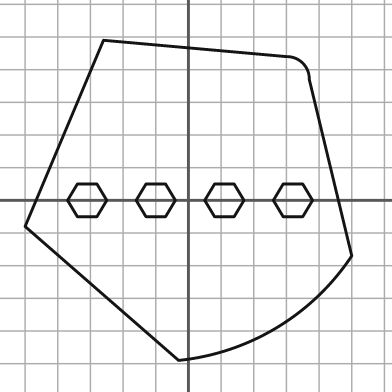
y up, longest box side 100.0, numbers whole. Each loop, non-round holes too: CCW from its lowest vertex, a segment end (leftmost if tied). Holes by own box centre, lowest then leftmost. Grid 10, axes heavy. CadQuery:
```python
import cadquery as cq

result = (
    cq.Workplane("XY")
    .moveTo(-3.0, -49.0)
    .threePointArc((27.0, -39.0), (50.0, -17.0))
    .lineTo(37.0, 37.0)
    .threePointArc((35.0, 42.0), (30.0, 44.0))
    .lineTo(-26.0, 49.0)
    .lineTo(-50.0, -8.0)
    .close()
    .moveTo(-34.0, -5.0)
    .lineTo(-28.0, -5.0)
    .lineTo(-25.0, 0.0)
    .lineTo(-28.0, 5.0)
    .lineTo(-34.0, 5.0)
    .lineTo(-37.0, 0.0)
    .close()
    .moveTo(-13.0, -5.0)
    .lineTo(-7.0, -5.0)
    .lineTo(-4.0, 0.0)
    .lineTo(-7.0, 5.0)
    .lineTo(-13.0, 5.0)
    .lineTo(-16.0, 0.0)
    .close()
    .moveTo(8.0, -5.0)
    .lineTo(14.0, -5.0)
    .lineTo(17.0, 0.0)
    .lineTo(14.0, 5.0)
    .lineTo(8.0, 5.0)
    .lineTo(5.0, 0.0)
    .close()
    .moveTo(29.0, -5.0)
    .lineTo(35.0, -5.0)
    .lineTo(38.0, 0.0)
    .lineTo(35.0, 5.0)
    .lineTo(29.0, 5.0)
    .lineTo(26.0, 0.0)
    .close()
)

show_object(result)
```